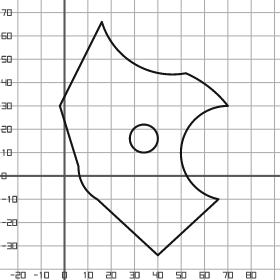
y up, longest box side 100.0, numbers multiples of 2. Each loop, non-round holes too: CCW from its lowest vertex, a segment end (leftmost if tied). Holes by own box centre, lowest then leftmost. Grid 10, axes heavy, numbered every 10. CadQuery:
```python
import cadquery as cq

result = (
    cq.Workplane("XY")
    .moveTo(40.0, -34.0)
    .lineTo(66.0, -10.0)
    .threePointArc((50.0, 12.0), (70.0, 30.0))
    .threePointArc((62.0, 38.0), (52.0, 44.0))
    .threePointArc((30.0, 48.0), (16.0, 66.0))
    .lineTo(-2.0, 30.0)
    .lineTo(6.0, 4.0)
    .threePointArc((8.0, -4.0), (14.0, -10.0))
    .close()
    .moveTo(34.0, 16.0)
    .circle(6.0)
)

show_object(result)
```